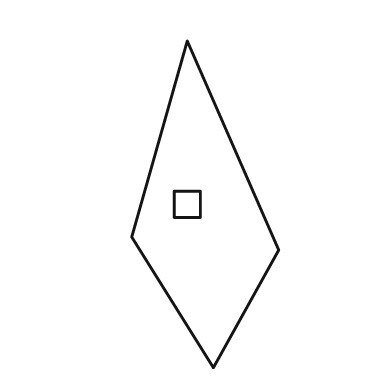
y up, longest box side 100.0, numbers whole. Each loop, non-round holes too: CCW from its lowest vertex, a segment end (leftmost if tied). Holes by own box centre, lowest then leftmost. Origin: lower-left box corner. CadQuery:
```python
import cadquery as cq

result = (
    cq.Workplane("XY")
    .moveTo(25.0, 0.0)
    .lineTo(45.0, 36.0)
    .lineTo(17.0, 100.0)
    .lineTo(0.0, 40.0)
    .close()
    .moveTo(13.0, 46.0)
    .lineTo(21.0, 46.0)
    .lineTo(21.0, 54.0)
    .lineTo(13.0, 54.0)
    .close()
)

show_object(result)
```